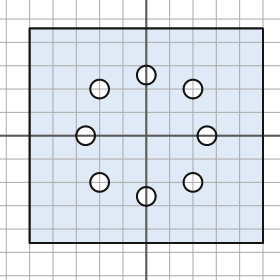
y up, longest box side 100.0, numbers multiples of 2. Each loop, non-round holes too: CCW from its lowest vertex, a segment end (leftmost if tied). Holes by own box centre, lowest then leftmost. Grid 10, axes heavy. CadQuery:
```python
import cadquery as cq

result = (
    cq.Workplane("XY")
    .moveTo(-50.0, -46.0)
    .lineTo(50.0, -46.0)
    .lineTo(50.0, 46.0)
    .lineTo(-50.0, 46.0)
    .close()
    .moveTo(0.0, -26.0)
    .circle(4.0)
    .moveTo(-20.0, -20.0)
    .circle(4.0)
    .moveTo(20.0, -20.0)
    .circle(4.0)
    .moveTo(-26.0, 0.0)
    .circle(4.0)
    .moveTo(26.0, 0.0)
    .circle(4.0)
    .moveTo(-20.0, 20.0)
    .circle(4.0)
    .moveTo(20.0, 20.0)
    .circle(4.0)
    .moveTo(0.0, 26.0)
    .circle(4.0)
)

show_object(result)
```